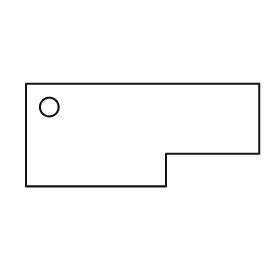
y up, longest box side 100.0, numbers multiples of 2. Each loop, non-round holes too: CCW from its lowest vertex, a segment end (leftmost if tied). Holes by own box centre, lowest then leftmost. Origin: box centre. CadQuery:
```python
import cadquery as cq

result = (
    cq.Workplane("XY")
    .moveTo(-50.0, -22.0)
    .lineTo(10.0, -22.0)
    .lineTo(10.0, -8.0)
    .lineTo(50.0, -8.0)
    .lineTo(50.0, 22.0)
    .lineTo(-50.0, 22.0)
    .close()
    .moveTo(-40.0, 12.0)
    .circle(4.0)
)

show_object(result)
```